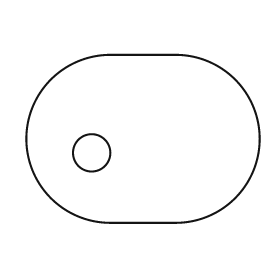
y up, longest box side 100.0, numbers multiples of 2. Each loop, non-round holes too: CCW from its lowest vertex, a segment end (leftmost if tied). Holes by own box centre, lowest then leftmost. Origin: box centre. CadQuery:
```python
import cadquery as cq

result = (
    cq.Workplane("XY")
    .moveTo(-14.0, -36.0)
    .lineTo(14.0, -36.0)
    .threePointArc((50.0, 0.0), (14.0, 36.0))
    .lineTo(-14.0, 36.0)
    .threePointArc((-50.0, 0.0), (-14.0, -36.0))
    .close()
    .moveTo(-22.0, -6.0)
    .circle(8.0)
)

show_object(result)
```